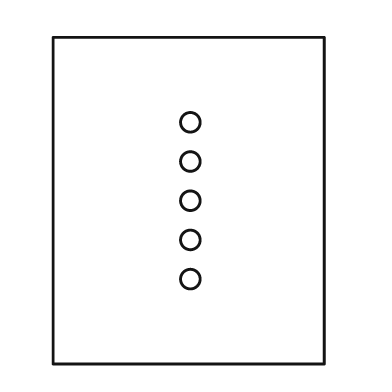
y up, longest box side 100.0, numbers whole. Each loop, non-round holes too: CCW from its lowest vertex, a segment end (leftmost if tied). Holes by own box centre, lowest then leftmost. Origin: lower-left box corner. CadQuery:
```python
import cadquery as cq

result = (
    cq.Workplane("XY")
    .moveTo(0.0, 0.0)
    .lineTo(83.0, 0.0)
    .lineTo(83.0, 100.0)
    .lineTo(0.0, 100.0)
    .close()
    .moveTo(42.0, 26.0)
    .circle(3.0)
    .moveTo(42.0, 38.0)
    .circle(3.0)
    .moveTo(42.0, 50.0)
    .circle(3.0)
    .moveTo(42.0, 62.0)
    .circle(3.0)
    .moveTo(42.0, 74.0)
    .circle(3.0)
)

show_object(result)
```